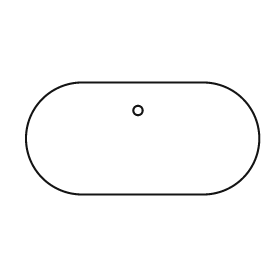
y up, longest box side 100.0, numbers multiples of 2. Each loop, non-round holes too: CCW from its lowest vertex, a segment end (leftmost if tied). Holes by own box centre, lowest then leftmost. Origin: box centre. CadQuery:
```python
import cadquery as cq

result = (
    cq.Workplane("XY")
    .moveTo(-26.0, -24.0)
    .lineTo(26.0, -24.0)
    .threePointArc((50.0, 0.0), (26.0, 24.0))
    .lineTo(-26.0, 24.0)
    .threePointArc((-50.0, 0.0), (-26.0, -24.0))
    .close()
    .moveTo(-2.0, 12.0)
    .circle(2.0)
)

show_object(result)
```